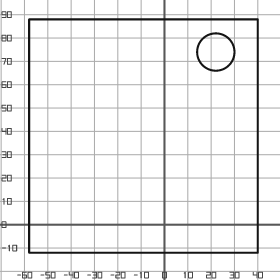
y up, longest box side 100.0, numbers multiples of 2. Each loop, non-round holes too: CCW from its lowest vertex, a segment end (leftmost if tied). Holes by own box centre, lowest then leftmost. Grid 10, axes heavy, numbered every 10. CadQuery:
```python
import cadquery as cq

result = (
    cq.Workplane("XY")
    .moveTo(-58.0, -12.0)
    .lineTo(40.0, -12.0)
    .lineTo(40.0, 88.0)
    .lineTo(-58.0, 88.0)
    .close()
    .moveTo(22.0, 74.0)
    .circle(8.0)
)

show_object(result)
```